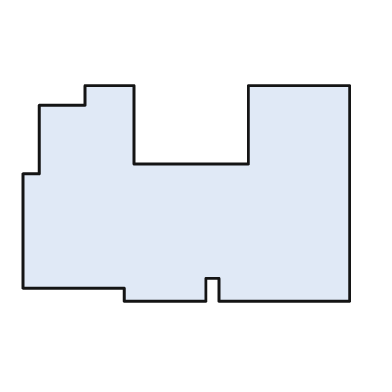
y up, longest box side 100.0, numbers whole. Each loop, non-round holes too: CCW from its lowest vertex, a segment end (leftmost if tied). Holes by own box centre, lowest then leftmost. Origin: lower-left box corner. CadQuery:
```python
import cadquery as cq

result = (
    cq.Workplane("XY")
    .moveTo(31.0, 0.0)
    .lineTo(56.0, 0.0)
    .lineTo(56.0, 7.0)
    .lineTo(60.0, 7.0)
    .lineTo(60.0, 0.0)
    .lineTo(100.0, 0.0)
    .lineTo(100.0, 66.0)
    .lineTo(69.0, 66.0)
    .lineTo(69.0, 42.0)
    .lineTo(34.0, 42.0)
    .lineTo(34.0, 66.0)
    .lineTo(19.0, 66.0)
    .lineTo(19.0, 60.0)
    .lineTo(5.0, 60.0)
    .lineTo(5.0, 39.0)
    .lineTo(0.0, 39.0)
    .lineTo(0.0, 4.0)
    .lineTo(31.0, 4.0)
    .close()
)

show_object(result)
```